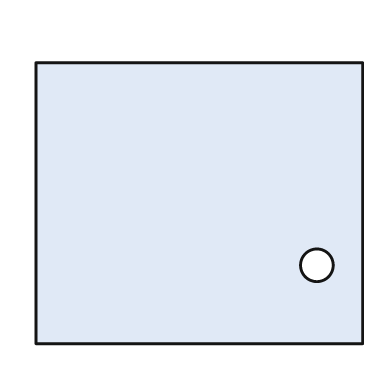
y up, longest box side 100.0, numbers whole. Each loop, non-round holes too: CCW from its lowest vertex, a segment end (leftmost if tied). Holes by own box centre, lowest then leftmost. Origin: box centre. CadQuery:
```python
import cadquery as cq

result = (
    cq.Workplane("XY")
    .moveTo(-50.0, -43.0)
    .lineTo(50.0, -43.0)
    .lineTo(50.0, 43.0)
    .lineTo(-50.0, 43.0)
    .close()
    .moveTo(36.0, -19.0)
    .circle(5.0)
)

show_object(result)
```